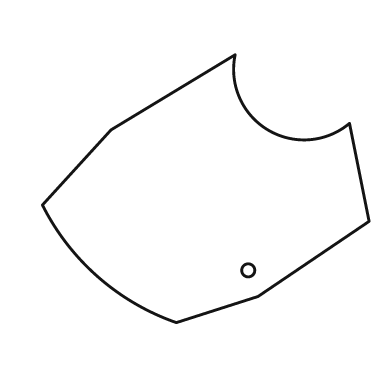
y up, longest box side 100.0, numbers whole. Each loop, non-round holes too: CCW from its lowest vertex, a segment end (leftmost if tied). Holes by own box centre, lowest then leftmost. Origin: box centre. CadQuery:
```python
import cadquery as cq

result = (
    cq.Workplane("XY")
    .moveTo(-9.0, -41.0)
    .lineTo(16.0, -33.0)
    .lineTo(50.0, -10.0)
    .lineTo(44.0, 20.0)
    .threePointArc((19.0, 18.0), (9.0, 41.0))
    .lineTo(-29.0, 18.0)
    .lineTo(-50.0, -5.0)
    .threePointArc((-33.0, -27.0), (-9.0, -41.0))
    .close()
    .moveTo(13.0, -25.0)
    .circle(2.0)
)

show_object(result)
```